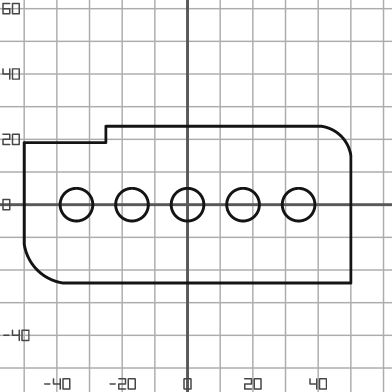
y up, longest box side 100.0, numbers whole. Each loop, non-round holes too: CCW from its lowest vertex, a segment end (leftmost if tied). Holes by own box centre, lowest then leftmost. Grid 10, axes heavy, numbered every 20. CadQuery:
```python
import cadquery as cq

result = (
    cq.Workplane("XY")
    .moveTo(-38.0, -24.0)
    .lineTo(50.0, -24.0)
    .lineTo(50.0, 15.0)
    .threePointArc((47.0, 21.0), (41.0, 24.0))
    .lineTo(-25.0, 24.0)
    .lineTo(-25.0, 19.0)
    .lineTo(-50.0, 19.0)
    .lineTo(-50.0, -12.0)
    .threePointArc((-46.0, -20.0), (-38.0, -24.0))
    .close()
    .moveTo(-34.0, 0.0)
    .circle(5.0)
    .moveTo(-17.0, 0.0)
    .circle(5.0)
    .moveTo(0.0, 0.0)
    .circle(5.0)
    .moveTo(17.0, 0.0)
    .circle(5.0)
    .moveTo(34.0, 0.0)
    .circle(5.0)
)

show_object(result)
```